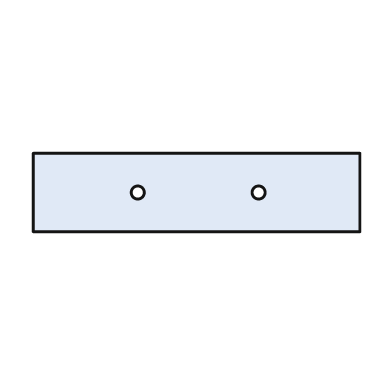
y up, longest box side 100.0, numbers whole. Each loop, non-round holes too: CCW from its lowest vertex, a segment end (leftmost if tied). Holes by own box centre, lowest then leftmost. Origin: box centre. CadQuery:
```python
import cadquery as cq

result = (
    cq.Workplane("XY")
    .moveTo(-50.0, -12.0)
    .lineTo(50.0, -12.0)
    .lineTo(50.0, 12.0)
    .lineTo(-50.0, 12.0)
    .close()
    .moveTo(-18.0, 0.0)
    .circle(2.0)
    .moveTo(19.0, 0.0)
    .circle(2.0)
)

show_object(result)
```